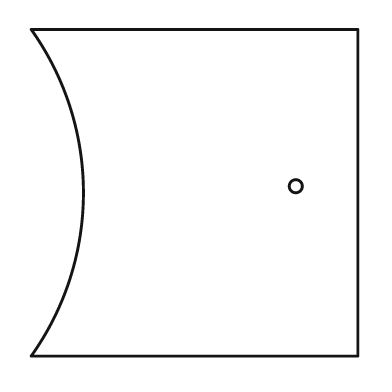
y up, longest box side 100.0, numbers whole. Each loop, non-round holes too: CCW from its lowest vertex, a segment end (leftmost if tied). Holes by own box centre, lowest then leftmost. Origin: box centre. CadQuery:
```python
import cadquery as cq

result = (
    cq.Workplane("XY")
    .moveTo(-50.0, -50.0)
    .lineTo(50.0, -50.0)
    .lineTo(50.0, 50.0)
    .lineTo(-50.0, 50.0)
    .threePointArc((-34.0, 0.0), (-50.0, -50.0))
    .close()
    .moveTo(31.0, 2.0)
    .circle(2.0)
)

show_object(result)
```